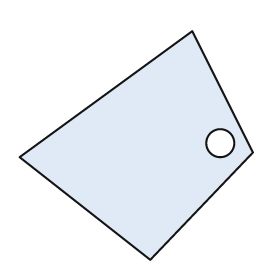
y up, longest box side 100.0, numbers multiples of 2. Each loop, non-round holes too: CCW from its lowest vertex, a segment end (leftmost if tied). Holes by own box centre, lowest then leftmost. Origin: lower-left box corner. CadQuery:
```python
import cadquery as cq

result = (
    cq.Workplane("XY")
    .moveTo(56.0, 0.0)
    .lineTo(100.0, 46.0)
    .lineTo(74.0, 98.0)
    .lineTo(0.0, 44.0)
    .close()
    .moveTo(86.0, 50.0)
    .circle(6.0)
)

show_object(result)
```